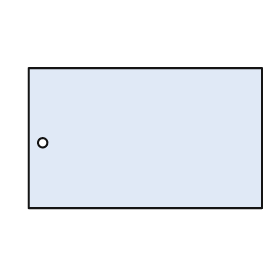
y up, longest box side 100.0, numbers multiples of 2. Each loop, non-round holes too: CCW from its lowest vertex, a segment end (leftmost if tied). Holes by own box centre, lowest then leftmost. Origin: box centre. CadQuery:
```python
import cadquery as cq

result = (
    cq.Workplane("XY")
    .moveTo(-50.0, -30.0)
    .lineTo(50.0, -30.0)
    .lineTo(50.0, 30.0)
    .lineTo(-50.0, 30.0)
    .close()
    .moveTo(-44.0, -2.0)
    .circle(2.0)
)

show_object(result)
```